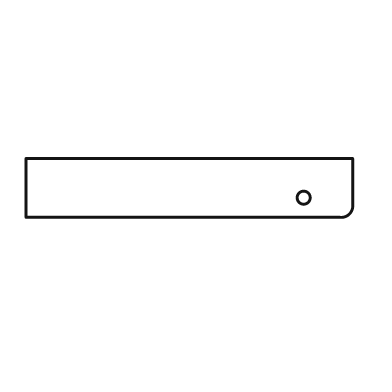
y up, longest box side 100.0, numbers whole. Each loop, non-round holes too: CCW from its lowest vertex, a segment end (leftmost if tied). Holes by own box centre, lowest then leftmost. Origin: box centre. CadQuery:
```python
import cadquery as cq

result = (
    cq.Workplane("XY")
    .moveTo(-50.0, -9.0)
    .lineTo(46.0, -9.0)
    .threePointArc((49.0, -8.0), (50.0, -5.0))
    .lineTo(50.0, 9.0)
    .lineTo(-50.0, 9.0)
    .close()
    .moveTo(35.0, -3.0)
    .circle(2.0)
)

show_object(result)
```